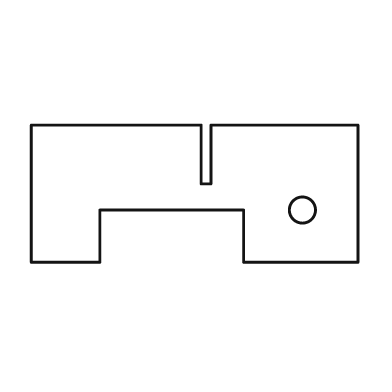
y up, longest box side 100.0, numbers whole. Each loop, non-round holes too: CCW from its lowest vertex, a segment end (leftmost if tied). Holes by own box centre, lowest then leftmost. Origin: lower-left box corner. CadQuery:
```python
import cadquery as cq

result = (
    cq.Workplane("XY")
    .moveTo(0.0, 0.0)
    .lineTo(21.0, 0.0)
    .lineTo(21.0, 16.0)
    .lineTo(65.0, 16.0)
    .lineTo(65.0, 0.0)
    .lineTo(100.0, 0.0)
    .lineTo(100.0, 42.0)
    .lineTo(55.0, 42.0)
    .lineTo(55.0, 24.0)
    .lineTo(52.0, 24.0)
    .lineTo(52.0, 42.0)
    .lineTo(0.0, 42.0)
    .close()
    .moveTo(83.0, 16.0)
    .circle(4.0)
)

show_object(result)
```